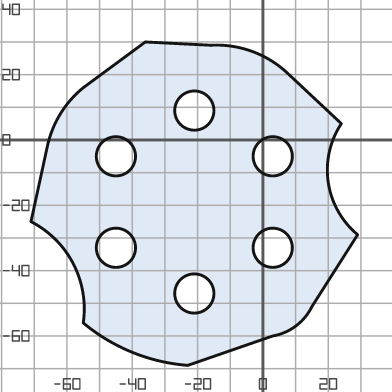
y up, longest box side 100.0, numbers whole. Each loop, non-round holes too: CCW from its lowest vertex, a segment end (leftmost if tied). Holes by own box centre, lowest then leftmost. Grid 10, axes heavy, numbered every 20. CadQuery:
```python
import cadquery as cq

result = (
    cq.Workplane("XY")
    .moveTo(-23.0, -69.0)
    .lineTo(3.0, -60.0)
    .threePointArc((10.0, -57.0), (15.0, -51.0))
    .lineTo(29.0, -29.0)
    .threePointArc((20.0, -13.0), (24.0, 5.0))
    .lineTo(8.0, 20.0)
    .threePointArc((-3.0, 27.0), (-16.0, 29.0))
    .lineTo(-36.0, 30.0)
    .lineTo(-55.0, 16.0)
    .threePointArc((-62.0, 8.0), (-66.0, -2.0))
    .lineTo(-71.0, -25.0)
    .threePointArc((-58.0, -38.0), (-55.0, -56.0))
    .threePointArc((-40.0, -65.0), (-23.0, -69.0))
    .close()
    .moveTo(-21.0, -47.0)
    .circle(6.0)
    .moveTo(-45.0, -33.0)
    .circle(6.0)
    .moveTo(3.0, -33.0)
    .circle(6.0)
    .moveTo(-45.0, -5.0)
    .circle(6.0)
    .moveTo(3.0, -5.0)
    .circle(6.0)
    .moveTo(-21.0, 9.0)
    .circle(6.0)
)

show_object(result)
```